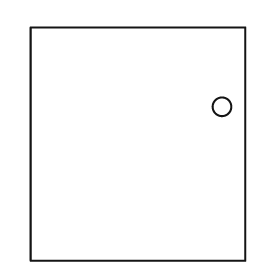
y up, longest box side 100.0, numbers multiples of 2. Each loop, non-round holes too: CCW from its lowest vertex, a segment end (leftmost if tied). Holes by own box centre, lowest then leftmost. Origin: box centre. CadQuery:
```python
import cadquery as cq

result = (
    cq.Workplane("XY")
    .moveTo(-46.0, -50.0)
    .lineTo(46.0, -50.0)
    .lineTo(46.0, 50.0)
    .lineTo(-46.0, 50.0)
    .close()
    .moveTo(36.0, 16.0)
    .circle(4.0)
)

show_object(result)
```